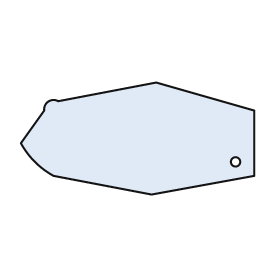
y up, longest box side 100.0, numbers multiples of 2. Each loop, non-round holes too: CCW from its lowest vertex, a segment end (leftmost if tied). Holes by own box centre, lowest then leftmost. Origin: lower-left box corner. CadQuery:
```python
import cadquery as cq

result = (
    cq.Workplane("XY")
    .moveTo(56.0, 0.0)
    .lineTo(100.0, 8.0)
    .lineTo(100.0, 36.0)
    .lineTo(58.0, 48.0)
    .lineTo(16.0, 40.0)
    .threePointArc((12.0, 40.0), (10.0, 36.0))
    .lineTo(0.0, 22.0)
    .threePointArc((6.0, 14.0), (14.0, 8.0))
    .close()
    .moveTo(92.0, 14.0)
    .circle(2.0)
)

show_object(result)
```